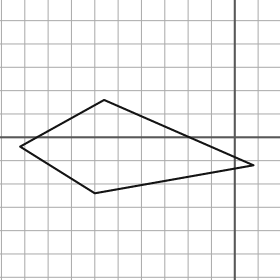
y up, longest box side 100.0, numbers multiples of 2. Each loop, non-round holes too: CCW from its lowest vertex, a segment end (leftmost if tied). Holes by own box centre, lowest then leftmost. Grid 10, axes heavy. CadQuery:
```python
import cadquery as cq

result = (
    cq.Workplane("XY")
    .moveTo(-60.0, -24.0)
    .lineTo(8.0, -12.0)
    .lineTo(-56.0, 16.0)
    .lineTo(-92.0, -4.0)
    .close()
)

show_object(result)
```